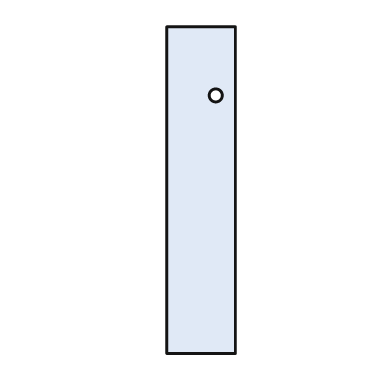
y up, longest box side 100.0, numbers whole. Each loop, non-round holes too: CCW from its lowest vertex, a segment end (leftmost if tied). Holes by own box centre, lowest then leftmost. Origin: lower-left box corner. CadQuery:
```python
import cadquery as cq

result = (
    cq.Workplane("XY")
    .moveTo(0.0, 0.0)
    .lineTo(21.0, 0.0)
    .lineTo(21.0, 100.0)
    .lineTo(0.0, 100.0)
    .close()
    .moveTo(15.0, 79.0)
    .circle(2.0)
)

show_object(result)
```